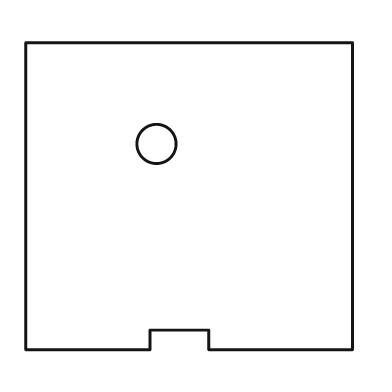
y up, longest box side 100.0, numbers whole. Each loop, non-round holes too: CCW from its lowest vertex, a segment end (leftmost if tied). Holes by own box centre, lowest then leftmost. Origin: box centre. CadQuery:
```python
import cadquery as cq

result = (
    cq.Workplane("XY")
    .moveTo(-50.0, -47.0)
    .lineTo(-12.0, -47.0)
    .lineTo(-12.0, -41.0)
    .lineTo(6.0, -41.0)
    .lineTo(6.0, -47.0)
    .lineTo(50.0, -47.0)
    .lineTo(50.0, 47.0)
    .lineTo(-50.0, 47.0)
    .close()
    .moveTo(-10.0, 16.0)
    .circle(6.0)
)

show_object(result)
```